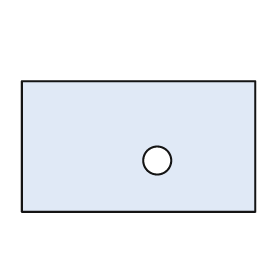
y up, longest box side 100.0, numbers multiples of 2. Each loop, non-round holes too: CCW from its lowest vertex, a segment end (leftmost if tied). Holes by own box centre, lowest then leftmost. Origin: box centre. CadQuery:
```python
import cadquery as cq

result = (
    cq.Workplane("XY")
    .moveTo(-50.0, -28.0)
    .lineTo(50.0, -28.0)
    .lineTo(50.0, 28.0)
    .lineTo(-50.0, 28.0)
    .close()
    .moveTo(8.0, -6.0)
    .circle(6.0)
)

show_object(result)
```